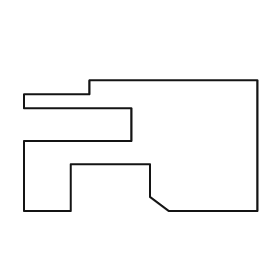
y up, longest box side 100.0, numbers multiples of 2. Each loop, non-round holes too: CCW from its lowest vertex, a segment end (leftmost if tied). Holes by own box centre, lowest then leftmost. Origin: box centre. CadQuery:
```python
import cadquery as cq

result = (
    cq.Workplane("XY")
    .moveTo(-50.0, -28.0)
    .lineTo(-30.0, -28.0)
    .lineTo(-30.0, -8.0)
    .lineTo(4.0, -8.0)
    .lineTo(4.0, -22.0)
    .lineTo(12.0, -28.0)
    .lineTo(50.0, -28.0)
    .lineTo(50.0, 28.0)
    .lineTo(-22.0, 28.0)
    .lineTo(-22.0, 22.0)
    .lineTo(-50.0, 22.0)
    .lineTo(-50.0, 16.0)
    .lineTo(-4.0, 16.0)
    .lineTo(-4.0, 2.0)
    .lineTo(-50.0, 2.0)
    .close()
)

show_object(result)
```